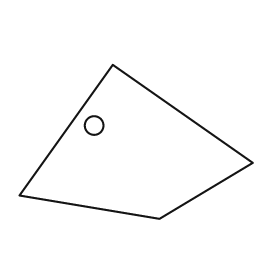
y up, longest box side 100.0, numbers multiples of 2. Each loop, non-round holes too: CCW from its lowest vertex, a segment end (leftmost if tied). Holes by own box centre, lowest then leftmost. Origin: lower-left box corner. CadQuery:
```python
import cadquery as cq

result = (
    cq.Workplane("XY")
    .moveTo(60.0, 0.0)
    .lineTo(100.0, 24.0)
    .lineTo(40.0, 66.0)
    .lineTo(0.0, 10.0)
    .close()
    .moveTo(32.0, 40.0)
    .circle(4.0)
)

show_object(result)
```